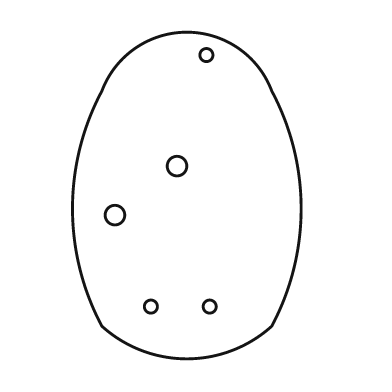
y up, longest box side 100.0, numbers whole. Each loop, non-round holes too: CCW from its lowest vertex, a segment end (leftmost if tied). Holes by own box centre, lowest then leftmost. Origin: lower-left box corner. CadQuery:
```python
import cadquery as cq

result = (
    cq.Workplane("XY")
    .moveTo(9.0, 10.0)
    .threePointArc((35.0, 0.0), (61.0, 10.0))
    .threePointArc((70.0, 46.0), (61.0, 82.0))
    .threePointArc((35.0, 100.0), (9.0, 82.0))
    .threePointArc((0.0, 46.0), (9.0, 10.0))
    .close()
    .moveTo(24.0, 16.0)
    .circle(2.0)
    .moveTo(42.0, 16.0)
    .circle(2.0)
    .moveTo(13.0, 44.0)
    .circle(3.0)
    .moveTo(32.0, 59.0)
    .circle(3.0)
    .moveTo(41.0, 93.0)
    .circle(2.0)
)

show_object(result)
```